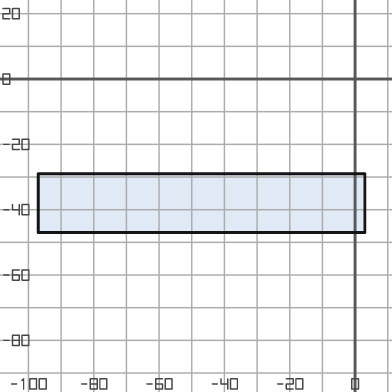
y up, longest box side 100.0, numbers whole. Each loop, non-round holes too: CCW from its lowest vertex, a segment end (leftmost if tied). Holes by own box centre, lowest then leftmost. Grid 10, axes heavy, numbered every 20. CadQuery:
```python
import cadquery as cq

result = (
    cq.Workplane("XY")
    .moveTo(-97.0, -47.0)
    .lineTo(3.0, -47.0)
    .lineTo(3.0, -29.0)
    .lineTo(-97.0, -29.0)
    .close()
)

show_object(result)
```